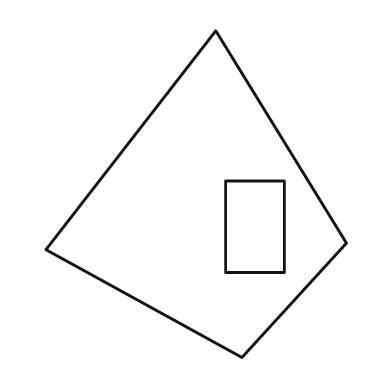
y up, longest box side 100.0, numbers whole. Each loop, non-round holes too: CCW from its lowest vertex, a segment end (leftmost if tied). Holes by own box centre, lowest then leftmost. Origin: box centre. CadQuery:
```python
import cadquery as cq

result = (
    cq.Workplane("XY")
    .moveTo(14.0, -50.0)
    .lineTo(46.0, -15.0)
    .lineTo(6.0, 50.0)
    .lineTo(-46.0, -17.0)
    .close()
    .moveTo(9.0, -24.0)
    .lineTo(27.0, -24.0)
    .lineTo(27.0, 4.0)
    .lineTo(9.0, 4.0)
    .close()
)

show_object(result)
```